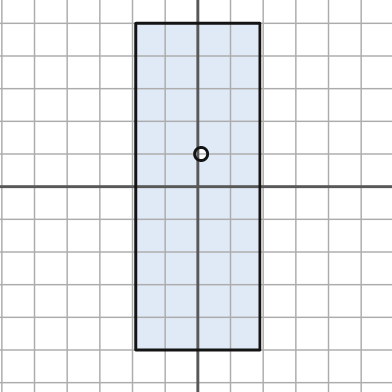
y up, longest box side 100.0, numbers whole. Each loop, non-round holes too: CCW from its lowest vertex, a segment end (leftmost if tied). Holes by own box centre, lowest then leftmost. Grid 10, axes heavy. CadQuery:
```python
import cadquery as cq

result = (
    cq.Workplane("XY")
    .moveTo(-19.0, -50.0)
    .lineTo(19.0, -50.0)
    .lineTo(19.0, 50.0)
    .lineTo(-19.0, 50.0)
    .close()
    .moveTo(1.0, 10.0)
    .circle(2.0)
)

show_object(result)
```